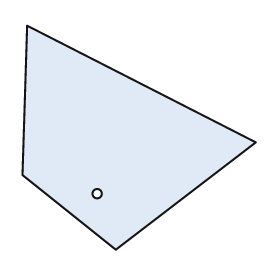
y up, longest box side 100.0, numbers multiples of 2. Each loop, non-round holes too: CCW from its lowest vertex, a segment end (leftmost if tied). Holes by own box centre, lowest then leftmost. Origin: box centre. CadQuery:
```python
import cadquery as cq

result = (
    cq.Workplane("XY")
    .moveTo(-10.0, -48.0)
    .lineTo(50.0, -2.0)
    .lineTo(-48.0, 48.0)
    .lineTo(-50.0, -16.0)
    .close()
    .moveTo(-18.0, -24.0)
    .circle(2.0)
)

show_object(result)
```